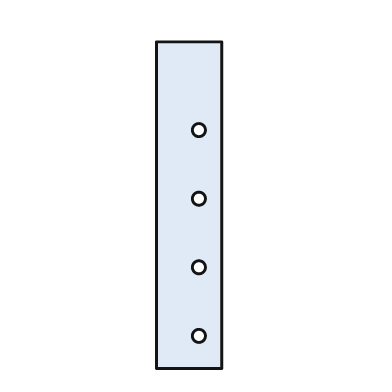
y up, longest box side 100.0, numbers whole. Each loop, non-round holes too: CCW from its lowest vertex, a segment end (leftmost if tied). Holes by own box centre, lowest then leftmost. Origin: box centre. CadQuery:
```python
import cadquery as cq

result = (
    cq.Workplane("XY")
    .moveTo(-10.0, -50.0)
    .lineTo(10.0, -50.0)
    .lineTo(10.0, 50.0)
    .lineTo(-10.0, 50.0)
    .close()
    .moveTo(3.0, -40.0)
    .circle(2.0)
    .moveTo(3.0, -19.0)
    .circle(2.0)
    .moveTo(3.0, 2.0)
    .circle(2.0)
    .moveTo(3.0, 23.0)
    .circle(2.0)
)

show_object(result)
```